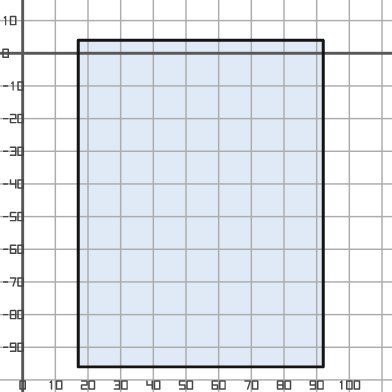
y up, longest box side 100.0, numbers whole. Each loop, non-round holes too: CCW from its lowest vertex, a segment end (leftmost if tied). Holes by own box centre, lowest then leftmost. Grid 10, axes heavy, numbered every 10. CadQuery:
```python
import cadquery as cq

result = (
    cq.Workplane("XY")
    .moveTo(17.0, -96.0)
    .lineTo(92.0, -96.0)
    .lineTo(92.0, 4.0)
    .lineTo(17.0, 4.0)
    .close()
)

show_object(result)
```